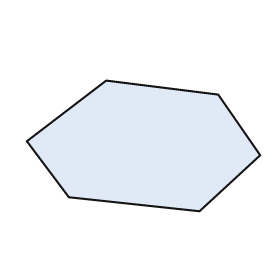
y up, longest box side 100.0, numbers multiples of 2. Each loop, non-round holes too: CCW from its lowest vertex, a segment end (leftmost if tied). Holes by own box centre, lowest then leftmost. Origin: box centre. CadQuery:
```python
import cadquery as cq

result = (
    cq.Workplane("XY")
    .moveTo(24.0, -28.0)
    .lineTo(50.0, -4.0)
    .lineTo(32.0, 22.0)
    .lineTo(-16.0, 28.0)
    .lineTo(-50.0, 2.0)
    .lineTo(-32.0, -22.0)
    .close()
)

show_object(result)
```